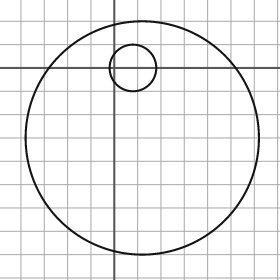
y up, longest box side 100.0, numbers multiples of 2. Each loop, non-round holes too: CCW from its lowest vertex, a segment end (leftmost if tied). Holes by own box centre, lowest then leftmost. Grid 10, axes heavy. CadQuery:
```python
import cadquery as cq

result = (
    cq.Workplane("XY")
    .moveTo(12.0, -30.0)
    .circle(50.0)
    .moveTo(8.0, 0.0)
    .circle(10.0)
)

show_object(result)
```